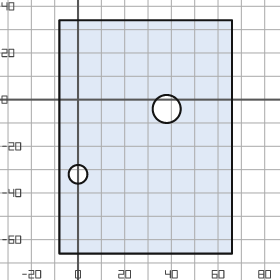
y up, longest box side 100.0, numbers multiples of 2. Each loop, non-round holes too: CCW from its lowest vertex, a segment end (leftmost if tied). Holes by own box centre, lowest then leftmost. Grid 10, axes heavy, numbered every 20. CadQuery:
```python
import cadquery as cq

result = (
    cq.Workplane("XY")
    .moveTo(-8.0, -66.0)
    .lineTo(66.0, -66.0)
    .lineTo(66.0, 34.0)
    .lineTo(-8.0, 34.0)
    .close()
    .moveTo(0.0, -32.0)
    .circle(4.0)
    .moveTo(38.0, -4.0)
    .circle(6.0)
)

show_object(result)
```